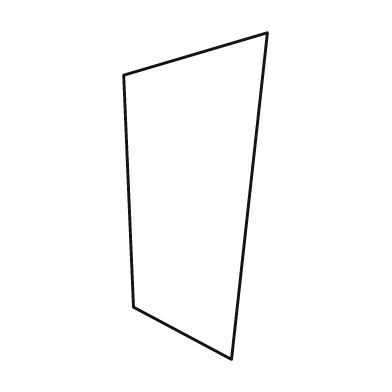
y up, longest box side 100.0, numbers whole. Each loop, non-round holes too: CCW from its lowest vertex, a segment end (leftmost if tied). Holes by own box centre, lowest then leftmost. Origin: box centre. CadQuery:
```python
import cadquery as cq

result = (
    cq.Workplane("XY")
    .moveTo(11.0, -50.0)
    .lineTo(22.0, 50.0)
    .lineTo(-22.0, 37.0)
    .lineTo(-19.0, -34.0)
    .close()
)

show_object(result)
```